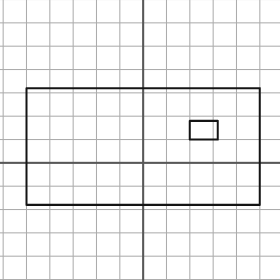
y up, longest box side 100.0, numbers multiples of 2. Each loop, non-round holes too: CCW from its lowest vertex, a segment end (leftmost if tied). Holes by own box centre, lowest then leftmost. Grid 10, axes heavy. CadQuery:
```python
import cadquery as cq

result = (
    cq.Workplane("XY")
    .moveTo(-50.0, -18.0)
    .lineTo(50.0, -18.0)
    .lineTo(50.0, 32.0)
    .lineTo(-50.0, 32.0)
    .close()
    .moveTo(20.0, 10.0)
    .lineTo(32.0, 10.0)
    .lineTo(32.0, 18.0)
    .lineTo(20.0, 18.0)
    .close()
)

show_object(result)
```